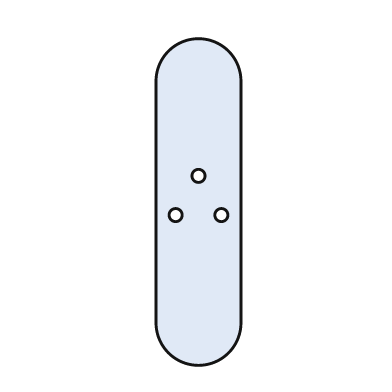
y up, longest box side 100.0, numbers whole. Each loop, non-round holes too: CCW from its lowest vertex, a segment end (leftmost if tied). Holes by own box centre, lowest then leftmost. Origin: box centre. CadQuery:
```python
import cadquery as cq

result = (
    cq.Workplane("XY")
    .moveTo(-13.0, -37.0)
    .threePointArc((0.0, -50.0), (13.0, -37.0))
    .lineTo(13.0, 37.0)
    .threePointArc((0.0, 50.0), (-13.0, 37.0))
    .close()
    .moveTo(-7.0, -4.0)
    .circle(2.0)
    .moveTo(7.0, -4.0)
    .circle(2.0)
    .moveTo(0.0, 8.0)
    .circle(2.0)
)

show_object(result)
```